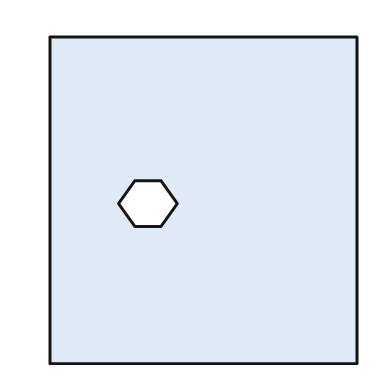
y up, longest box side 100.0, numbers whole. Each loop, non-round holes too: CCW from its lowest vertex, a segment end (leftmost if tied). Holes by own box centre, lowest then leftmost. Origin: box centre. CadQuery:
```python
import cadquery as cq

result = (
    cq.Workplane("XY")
    .moveTo(-47.0, -50.0)
    .lineTo(47.0, -50.0)
    .lineTo(47.0, 50.0)
    .lineTo(-47.0, 50.0)
    .close()
    .moveTo(-21.0, -8.0)
    .lineTo(-13.0, -8.0)
    .lineTo(-8.0, -1.0)
    .lineTo(-13.0, 6.0)
    .lineTo(-21.0, 6.0)
    .lineTo(-26.0, -1.0)
    .close()
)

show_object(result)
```